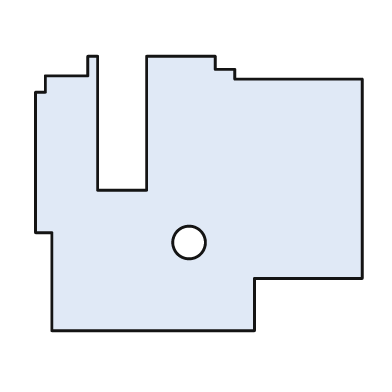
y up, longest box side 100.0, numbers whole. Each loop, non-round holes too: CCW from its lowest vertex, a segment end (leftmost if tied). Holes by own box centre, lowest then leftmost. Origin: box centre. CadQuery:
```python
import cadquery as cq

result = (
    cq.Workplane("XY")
    .moveTo(-45.0, -42.0)
    .lineTo(17.0, -42.0)
    .lineTo(17.0, -26.0)
    .lineTo(50.0, -26.0)
    .lineTo(50.0, 35.0)
    .lineTo(11.0, 35.0)
    .lineTo(11.0, 38.0)
    .lineTo(5.0, 38.0)
    .lineTo(5.0, 42.0)
    .lineTo(-16.0, 42.0)
    .lineTo(-16.0, 1.0)
    .lineTo(-31.0, 1.0)
    .lineTo(-31.0, 42.0)
    .lineTo(-34.0, 42.0)
    .lineTo(-34.0, 36.0)
    .lineTo(-47.0, 36.0)
    .lineTo(-47.0, 31.0)
    .lineTo(-50.0, 31.0)
    .lineTo(-50.0, -12.0)
    .lineTo(-45.0, -12.0)
    .close()
    .moveTo(-3.0, -15.0)
    .circle(5.0)
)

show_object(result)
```